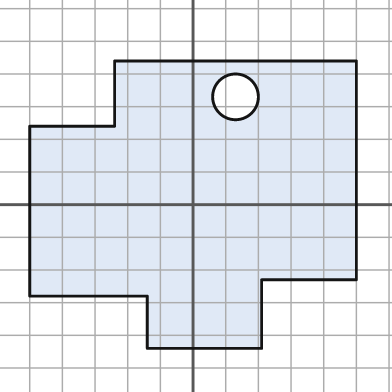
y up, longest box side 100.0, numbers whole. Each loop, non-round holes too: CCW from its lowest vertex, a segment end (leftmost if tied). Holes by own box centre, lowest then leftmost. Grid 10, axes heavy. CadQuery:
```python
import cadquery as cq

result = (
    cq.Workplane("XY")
    .moveTo(-14.0, -44.0)
    .lineTo(21.0, -44.0)
    .lineTo(21.0, -23.0)
    .lineTo(50.0, -23.0)
    .lineTo(50.0, 44.0)
    .lineTo(-24.0, 44.0)
    .lineTo(-24.0, 24.0)
    .lineTo(-50.0, 24.0)
    .lineTo(-50.0, -28.0)
    .lineTo(-14.0, -28.0)
    .close()
    .moveTo(13.0, 33.0)
    .circle(7.0)
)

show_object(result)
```